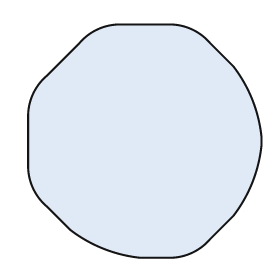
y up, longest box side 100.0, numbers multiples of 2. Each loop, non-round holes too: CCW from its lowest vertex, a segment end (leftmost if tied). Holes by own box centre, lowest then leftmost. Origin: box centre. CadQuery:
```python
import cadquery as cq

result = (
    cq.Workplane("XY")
    .moveTo(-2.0, -50.0)
    .lineTo(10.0, -50.0)
    .threePointArc((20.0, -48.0), (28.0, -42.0))
    .lineTo(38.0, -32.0)
    .threePointArc((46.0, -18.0), (50.0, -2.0))
    .lineTo(50.0, 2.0)
    .threePointArc((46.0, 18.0), (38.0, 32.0))
    .lineTo(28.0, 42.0)
    .threePointArc((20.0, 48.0), (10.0, 50.0))
    .lineTo(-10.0, 50.0)
    .threePointArc((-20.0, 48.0), (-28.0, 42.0))
    .lineTo(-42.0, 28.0)
    .threePointArc((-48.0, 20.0), (-50.0, 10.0))
    .lineTo(-50.0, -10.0)
    .threePointArc((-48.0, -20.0), (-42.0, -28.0))
    .lineTo(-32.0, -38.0)
    .threePointArc((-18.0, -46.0), (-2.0, -50.0))
    .close()
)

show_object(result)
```